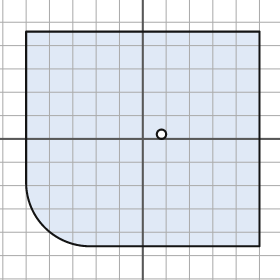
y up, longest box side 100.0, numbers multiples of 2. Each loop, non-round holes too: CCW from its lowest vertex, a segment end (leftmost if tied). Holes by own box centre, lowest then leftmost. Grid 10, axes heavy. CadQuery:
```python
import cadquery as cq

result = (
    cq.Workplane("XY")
    .moveTo(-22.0, -46.0)
    .lineTo(50.0, -46.0)
    .lineTo(50.0, 46.0)
    .lineTo(-50.0, 46.0)
    .lineTo(-50.0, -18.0)
    .threePointArc((-42.0, -38.0), (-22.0, -46.0))
    .close()
    .moveTo(8.0, 2.0)
    .circle(2.0)
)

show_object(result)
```